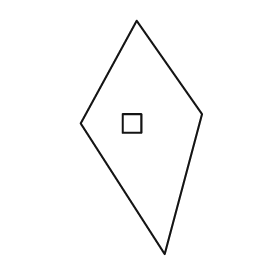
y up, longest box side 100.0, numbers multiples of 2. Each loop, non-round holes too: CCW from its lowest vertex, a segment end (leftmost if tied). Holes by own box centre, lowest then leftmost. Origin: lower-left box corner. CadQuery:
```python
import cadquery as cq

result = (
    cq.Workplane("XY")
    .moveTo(36.0, 0.0)
    .lineTo(52.0, 60.0)
    .lineTo(24.0, 100.0)
    .lineTo(0.0, 56.0)
    .close()
    .moveTo(18.0, 52.0)
    .lineTo(26.0, 52.0)
    .lineTo(26.0, 60.0)
    .lineTo(18.0, 60.0)
    .close()
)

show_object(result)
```